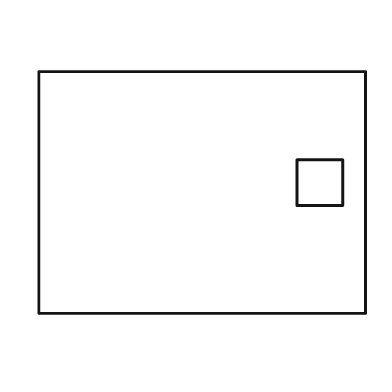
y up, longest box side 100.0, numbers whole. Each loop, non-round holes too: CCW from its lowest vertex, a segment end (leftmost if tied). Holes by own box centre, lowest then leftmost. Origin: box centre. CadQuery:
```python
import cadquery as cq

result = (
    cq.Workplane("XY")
    .moveTo(-50.0, -37.0)
    .lineTo(50.0, -37.0)
    .lineTo(50.0, 37.0)
    .lineTo(-50.0, 37.0)
    .close()
    .moveTo(29.0, -4.0)
    .lineTo(43.0, -4.0)
    .lineTo(43.0, 10.0)
    .lineTo(29.0, 10.0)
    .close()
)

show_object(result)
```